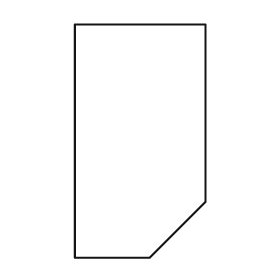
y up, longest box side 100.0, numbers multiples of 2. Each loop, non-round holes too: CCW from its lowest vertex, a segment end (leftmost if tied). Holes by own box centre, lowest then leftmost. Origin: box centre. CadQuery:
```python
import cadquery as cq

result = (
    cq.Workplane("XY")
    .moveTo(-28.0, -50.0)
    .lineTo(4.0, -50.0)
    .lineTo(28.0, -26.0)
    .lineTo(28.0, 50.0)
    .lineTo(-28.0, 50.0)
    .close()
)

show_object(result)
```